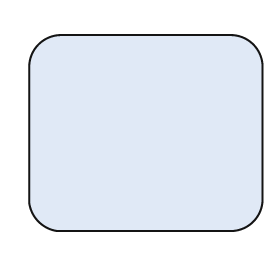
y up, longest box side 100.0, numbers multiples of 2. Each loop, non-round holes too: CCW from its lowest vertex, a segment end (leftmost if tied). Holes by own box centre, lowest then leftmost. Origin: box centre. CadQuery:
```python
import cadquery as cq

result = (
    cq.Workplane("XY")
    .moveTo(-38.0, -42.0)
    .lineTo(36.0, -42.0)
    .threePointArc((46.0, -38.0), (50.0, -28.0))
    .lineTo(50.0, 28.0)
    .threePointArc((46.0, 38.0), (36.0, 42.0))
    .lineTo(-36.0, 42.0)
    .threePointArc((-46.0, 38.0), (-50.0, 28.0))
    .lineTo(-50.0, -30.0)
    .threePointArc((-46.0, -38.0), (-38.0, -42.0))
    .close()
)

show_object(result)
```